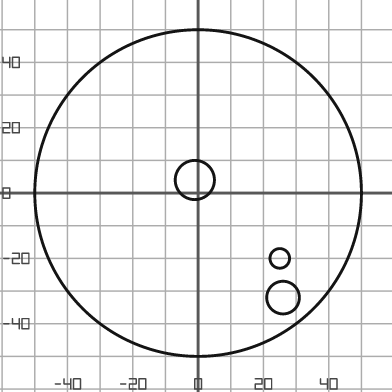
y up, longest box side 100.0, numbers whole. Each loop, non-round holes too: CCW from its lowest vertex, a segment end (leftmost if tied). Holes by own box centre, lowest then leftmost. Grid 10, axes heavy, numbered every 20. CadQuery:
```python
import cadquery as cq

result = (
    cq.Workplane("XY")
    .moveTo(0.0, 0.0)
    .circle(50.0)
    .moveTo(26.0, -32.0)
    .circle(5.0)
    .moveTo(25.0, -20.0)
    .circle(3.0)
    .moveTo(-1.0, 4.0)
    .circle(6.0)
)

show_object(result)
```